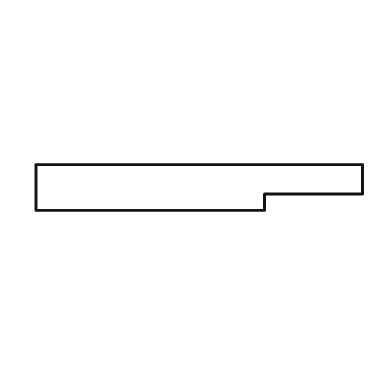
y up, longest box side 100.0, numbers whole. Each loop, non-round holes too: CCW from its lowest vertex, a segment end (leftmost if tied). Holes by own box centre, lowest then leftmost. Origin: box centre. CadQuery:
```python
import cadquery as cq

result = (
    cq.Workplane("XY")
    .moveTo(-50.0, -7.0)
    .lineTo(20.0, -7.0)
    .lineTo(20.0, -2.0)
    .lineTo(50.0, -2.0)
    .lineTo(50.0, 7.0)
    .lineTo(-50.0, 7.0)
    .close()
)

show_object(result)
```